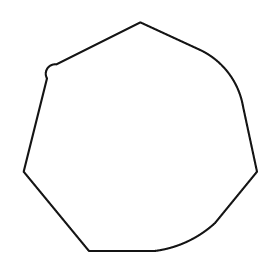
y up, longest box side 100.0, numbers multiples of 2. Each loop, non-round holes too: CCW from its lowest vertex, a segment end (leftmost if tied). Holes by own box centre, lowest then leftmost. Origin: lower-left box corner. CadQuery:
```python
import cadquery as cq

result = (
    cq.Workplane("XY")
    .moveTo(28.0, 0.0)
    .lineTo(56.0, 0.0)
    .threePointArc((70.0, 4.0), (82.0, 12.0))
    .lineTo(100.0, 34.0)
    .lineTo(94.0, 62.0)
    .threePointArc((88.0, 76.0), (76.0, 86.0))
    .lineTo(50.0, 98.0)
    .lineTo(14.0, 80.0)
    .threePointArc((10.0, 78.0), (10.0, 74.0))
    .lineTo(0.0, 34.0)
    .close()
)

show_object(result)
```